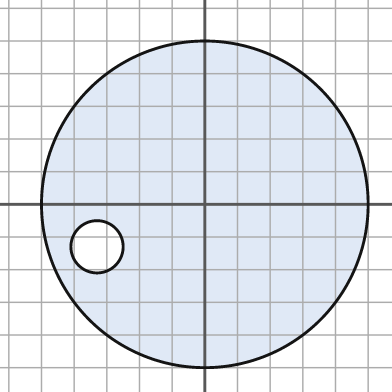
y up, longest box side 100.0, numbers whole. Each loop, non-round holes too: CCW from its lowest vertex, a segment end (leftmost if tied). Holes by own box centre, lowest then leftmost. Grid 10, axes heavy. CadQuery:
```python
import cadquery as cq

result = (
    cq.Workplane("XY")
    .moveTo(0.0, 0.0)
    .circle(50.0)
    .moveTo(-33.0, -13.0)
    .circle(8.0)
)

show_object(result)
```